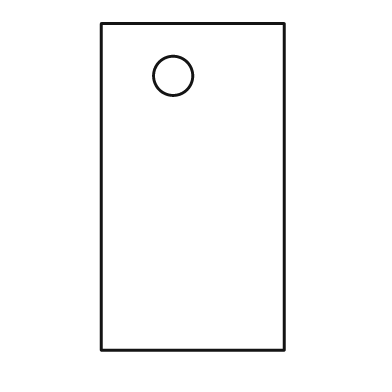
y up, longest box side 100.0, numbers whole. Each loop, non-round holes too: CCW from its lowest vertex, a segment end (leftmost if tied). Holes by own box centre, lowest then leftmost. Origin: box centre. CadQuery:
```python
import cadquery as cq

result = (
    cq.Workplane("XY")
    .moveTo(-28.0, -50.0)
    .lineTo(28.0, -50.0)
    .lineTo(28.0, 50.0)
    .lineTo(-28.0, 50.0)
    .close()
    .moveTo(-6.0, 34.0)
    .circle(6.0)
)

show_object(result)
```